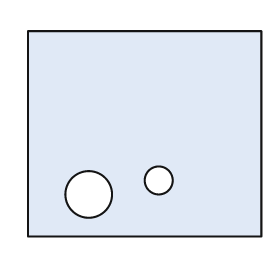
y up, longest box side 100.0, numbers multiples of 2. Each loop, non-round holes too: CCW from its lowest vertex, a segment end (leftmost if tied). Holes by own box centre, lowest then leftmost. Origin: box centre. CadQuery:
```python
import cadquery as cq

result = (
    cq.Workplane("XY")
    .moveTo(-50.0, -44.0)
    .lineTo(50.0, -44.0)
    .lineTo(50.0, 44.0)
    .lineTo(-50.0, 44.0)
    .close()
    .moveTo(-24.0, -26.0)
    .circle(10.0)
    .moveTo(6.0, -20.0)
    .circle(6.0)
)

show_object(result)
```